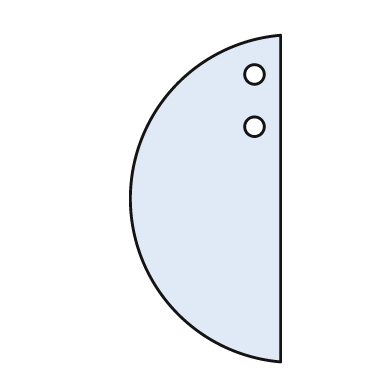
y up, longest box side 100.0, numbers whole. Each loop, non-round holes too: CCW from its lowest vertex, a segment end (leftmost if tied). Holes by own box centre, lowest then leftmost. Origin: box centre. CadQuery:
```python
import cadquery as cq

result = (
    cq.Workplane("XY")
    .moveTo(23.0, -50.0)
    .lineTo(23.0, 50.0)
    .threePointArc((-23.0, 0.0), (23.0, -50.0))
    .close()
    .moveTo(15.0, 22.0)
    .circle(3.0)
    .moveTo(15.0, 38.0)
    .circle(3.0)
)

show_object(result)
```